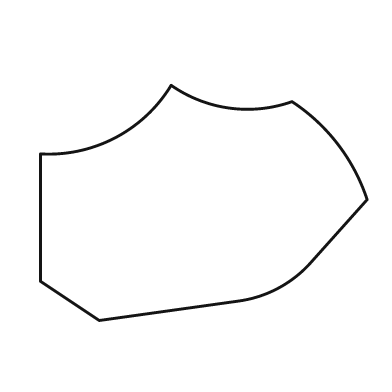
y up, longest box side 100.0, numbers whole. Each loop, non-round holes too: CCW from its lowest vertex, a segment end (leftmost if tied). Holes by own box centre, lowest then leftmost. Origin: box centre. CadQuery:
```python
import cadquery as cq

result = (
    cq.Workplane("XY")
    .moveTo(-32.0, -36.0)
    .lineTo(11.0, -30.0)
    .threePointArc((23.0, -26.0), (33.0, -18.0))
    .lineTo(50.0, 1.0)
    .threePointArc((41.0, 18.0), (27.0, 31.0))
    .threePointArc((8.0, 29.0), (-10.0, 36.0))
    .threePointArc((-27.0, 20.0), (-50.0, 15.0))
    .lineTo(-50.0, -24.0)
    .close()
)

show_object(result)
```